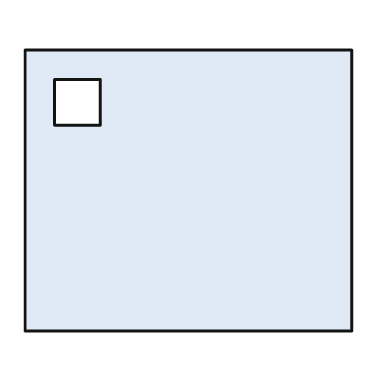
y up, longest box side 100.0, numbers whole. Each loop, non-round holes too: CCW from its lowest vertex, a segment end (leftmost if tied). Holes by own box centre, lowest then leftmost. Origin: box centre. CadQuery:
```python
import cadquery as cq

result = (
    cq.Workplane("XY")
    .moveTo(-50.0, -43.0)
    .lineTo(50.0, -43.0)
    .lineTo(50.0, 43.0)
    .lineTo(-50.0, 43.0)
    .close()
    .moveTo(-41.0, 20.0)
    .lineTo(-27.0, 20.0)
    .lineTo(-27.0, 34.0)
    .lineTo(-41.0, 34.0)
    .close()
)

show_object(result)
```